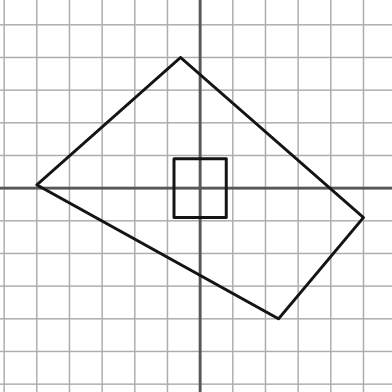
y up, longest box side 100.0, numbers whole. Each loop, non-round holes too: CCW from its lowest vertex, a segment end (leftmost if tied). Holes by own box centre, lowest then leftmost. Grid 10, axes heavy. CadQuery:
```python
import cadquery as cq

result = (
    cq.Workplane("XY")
    .moveTo(24.0, -40.0)
    .lineTo(50.0, -9.0)
    .lineTo(-6.0, 40.0)
    .lineTo(-50.0, 1.0)
    .close()
    .moveTo(-8.0, -9.0)
    .lineTo(8.0, -9.0)
    .lineTo(8.0, 9.0)
    .lineTo(-8.0, 9.0)
    .close()
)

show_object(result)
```